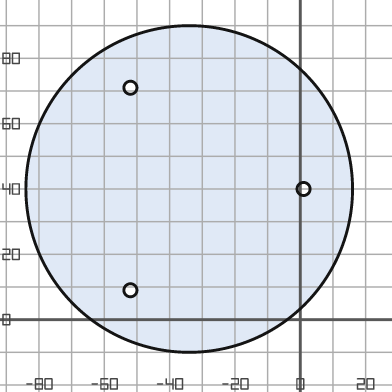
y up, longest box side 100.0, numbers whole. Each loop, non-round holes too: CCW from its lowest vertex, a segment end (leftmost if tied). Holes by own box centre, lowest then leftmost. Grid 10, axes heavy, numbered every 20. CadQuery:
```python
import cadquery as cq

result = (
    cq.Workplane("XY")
    .moveTo(-34.0, 40.0)
    .circle(50.0)
    .moveTo(-52.0, 9.0)
    .circle(2.0)
    .moveTo(1.0, 40.0)
    .circle(2.0)
    .moveTo(-52.0, 71.0)
    .circle(2.0)
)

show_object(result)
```